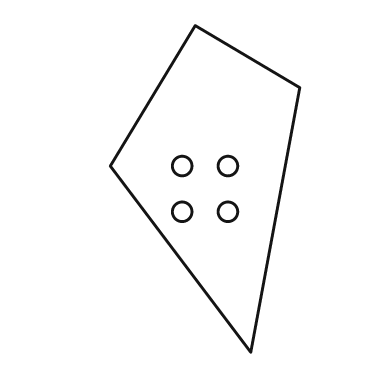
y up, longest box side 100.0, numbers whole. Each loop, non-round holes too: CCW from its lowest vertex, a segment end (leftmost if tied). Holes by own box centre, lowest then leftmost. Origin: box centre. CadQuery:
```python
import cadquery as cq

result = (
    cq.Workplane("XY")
    .moveTo(14.0, -50.0)
    .lineTo(29.0, 31.0)
    .lineTo(-3.0, 50.0)
    .lineTo(-29.0, 7.0)
    .close()
    .moveTo(-7.0, -7.0)
    .circle(3.0)
    .moveTo(7.0, -7.0)
    .circle(3.0)
    .moveTo(-7.0, 7.0)
    .circle(3.0)
    .moveTo(7.0, 7.0)
    .circle(3.0)
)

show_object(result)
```